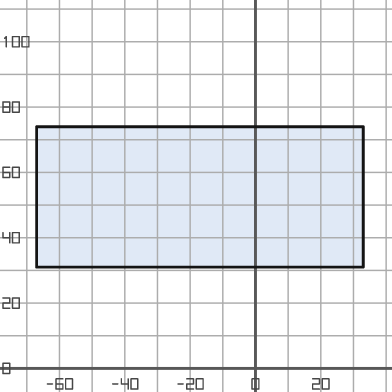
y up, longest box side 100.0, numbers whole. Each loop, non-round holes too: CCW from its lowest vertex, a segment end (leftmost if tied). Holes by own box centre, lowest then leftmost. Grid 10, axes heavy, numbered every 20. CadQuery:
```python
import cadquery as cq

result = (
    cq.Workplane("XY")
    .moveTo(-67.0, 31.0)
    .lineTo(33.0, 31.0)
    .lineTo(33.0, 74.0)
    .lineTo(-67.0, 74.0)
    .close()
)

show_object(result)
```